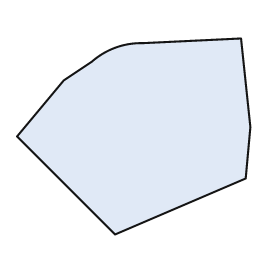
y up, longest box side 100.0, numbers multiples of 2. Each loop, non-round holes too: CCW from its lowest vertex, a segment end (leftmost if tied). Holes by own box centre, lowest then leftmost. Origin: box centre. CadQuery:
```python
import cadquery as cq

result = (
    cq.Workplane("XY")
    .moveTo(-8.0, -42.0)
    .lineTo(48.0, -18.0)
    .lineTo(50.0, 4.0)
    .lineTo(46.0, 42.0)
    .lineTo(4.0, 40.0)
    .threePointArc((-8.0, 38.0), (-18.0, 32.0))
    .lineTo(-30.0, 24.0)
    .lineTo(-50.0, 0.0)
    .close()
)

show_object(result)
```